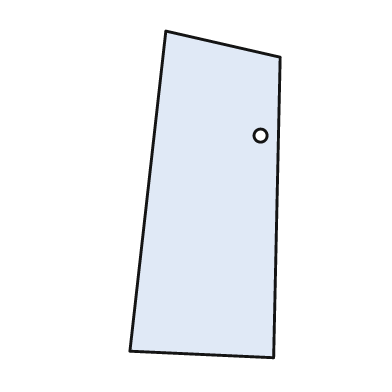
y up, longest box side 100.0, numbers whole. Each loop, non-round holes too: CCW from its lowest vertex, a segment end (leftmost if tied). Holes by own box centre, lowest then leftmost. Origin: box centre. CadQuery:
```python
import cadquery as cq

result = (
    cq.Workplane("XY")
    .moveTo(21.0, -50.0)
    .lineTo(23.0, 42.0)
    .lineTo(-12.0, 50.0)
    .lineTo(-23.0, -48.0)
    .close()
    .moveTo(17.0, 18.0)
    .circle(2.0)
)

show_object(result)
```